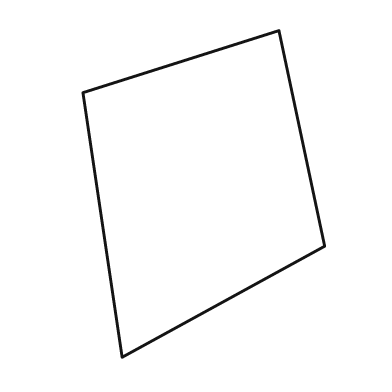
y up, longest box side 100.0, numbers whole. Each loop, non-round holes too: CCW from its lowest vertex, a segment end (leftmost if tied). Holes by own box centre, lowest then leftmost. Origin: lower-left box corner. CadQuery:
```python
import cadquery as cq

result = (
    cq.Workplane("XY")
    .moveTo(12.0, 0.0)
    .lineTo(74.0, 34.0)
    .lineTo(60.0, 100.0)
    .lineTo(0.0, 81.0)
    .close()
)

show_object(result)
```